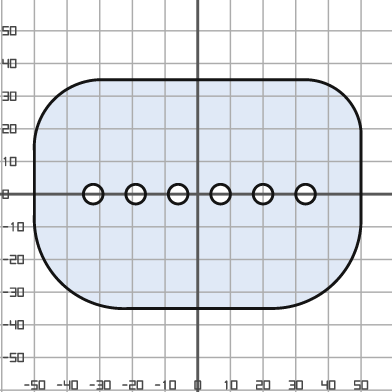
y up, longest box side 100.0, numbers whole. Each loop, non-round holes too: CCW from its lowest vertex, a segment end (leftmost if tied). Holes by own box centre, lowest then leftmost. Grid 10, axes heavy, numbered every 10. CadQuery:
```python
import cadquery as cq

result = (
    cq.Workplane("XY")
    .moveTo(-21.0, -35.0)
    .lineTo(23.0, -35.0)
    .threePointArc((42.0, -27.0), (50.0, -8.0))
    .lineTo(50.0, 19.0)
    .threePointArc((45.0, 30.0), (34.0, 35.0))
    .lineTo(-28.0, 35.0)
    .threePointArc((-44.0, 29.0), (-50.0, 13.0))
    .lineTo(-50.0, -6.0)
    .threePointArc((-42.0, -27.0), (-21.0, -35.0))
    .close()
    .moveTo(-32.0, 0.0)
    .circle(3.0)
    .moveTo(-19.0, 0.0)
    .circle(3.0)
    .moveTo(-6.0, 0.0)
    .circle(3.0)
    .moveTo(7.0, 0.0)
    .circle(3.0)
    .moveTo(20.0, 0.0)
    .circle(3.0)
    .moveTo(33.0, 0.0)
    .circle(3.0)
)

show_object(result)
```